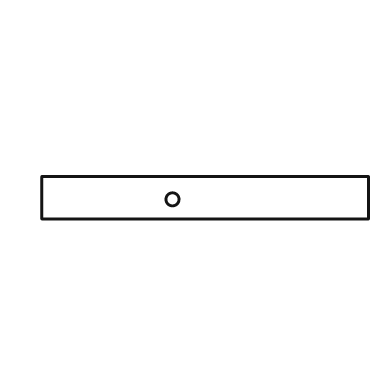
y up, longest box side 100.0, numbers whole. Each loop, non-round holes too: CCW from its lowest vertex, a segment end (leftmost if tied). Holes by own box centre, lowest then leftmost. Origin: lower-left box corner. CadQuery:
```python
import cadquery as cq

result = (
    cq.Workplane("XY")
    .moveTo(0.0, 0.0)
    .lineTo(100.0, 0.0)
    .lineTo(100.0, 13.0)
    .lineTo(0.0, 13.0)
    .close()
    .moveTo(40.0, 6.0)
    .circle(2.0)
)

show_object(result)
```